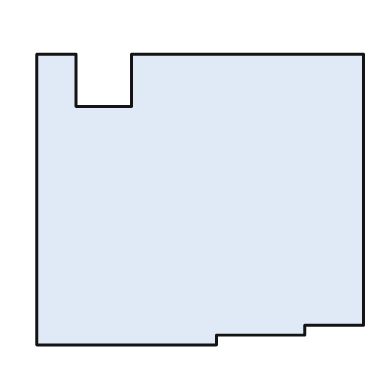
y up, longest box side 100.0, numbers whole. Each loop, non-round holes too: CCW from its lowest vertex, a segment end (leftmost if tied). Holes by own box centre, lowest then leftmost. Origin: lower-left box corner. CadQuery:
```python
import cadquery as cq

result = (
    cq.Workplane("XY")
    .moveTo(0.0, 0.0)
    .lineTo(55.0, 0.0)
    .lineTo(55.0, 3.0)
    .lineTo(82.0, 3.0)
    .lineTo(82.0, 6.0)
    .lineTo(100.0, 6.0)
    .lineTo(100.0, 89.0)
    .lineTo(29.0, 89.0)
    .lineTo(29.0, 73.0)
    .lineTo(12.0, 73.0)
    .lineTo(12.0, 89.0)
    .lineTo(0.0, 89.0)
    .close()
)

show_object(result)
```